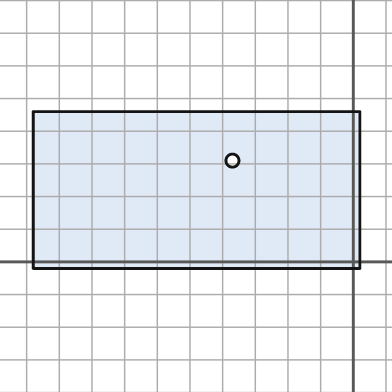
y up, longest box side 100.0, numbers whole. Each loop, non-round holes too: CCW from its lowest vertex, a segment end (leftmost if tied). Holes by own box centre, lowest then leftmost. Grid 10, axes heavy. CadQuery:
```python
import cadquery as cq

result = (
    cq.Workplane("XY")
    .moveTo(-98.0, -2.0)
    .lineTo(2.0, -2.0)
    .lineTo(2.0, 46.0)
    .lineTo(-98.0, 46.0)
    .close()
    .moveTo(-37.0, 31.0)
    .circle(2.0)
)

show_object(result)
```